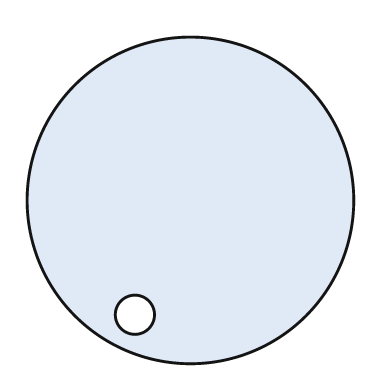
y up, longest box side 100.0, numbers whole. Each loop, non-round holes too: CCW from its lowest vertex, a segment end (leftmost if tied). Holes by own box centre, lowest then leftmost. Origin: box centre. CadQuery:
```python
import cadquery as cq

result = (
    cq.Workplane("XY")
    .moveTo(0.0, 0.0)
    .circle(50.0)
    .moveTo(-17.0, -35.0)
    .circle(6.0)
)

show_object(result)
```